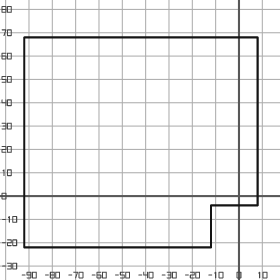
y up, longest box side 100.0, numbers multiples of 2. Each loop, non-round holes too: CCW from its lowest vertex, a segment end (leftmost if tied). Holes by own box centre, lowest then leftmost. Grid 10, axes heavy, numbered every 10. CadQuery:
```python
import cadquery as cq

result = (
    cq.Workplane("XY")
    .moveTo(-92.0, -22.0)
    .lineTo(-12.0, -22.0)
    .lineTo(-12.0, -4.0)
    .lineTo(8.0, -4.0)
    .lineTo(8.0, 68.0)
    .lineTo(-92.0, 68.0)
    .close()
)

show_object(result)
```